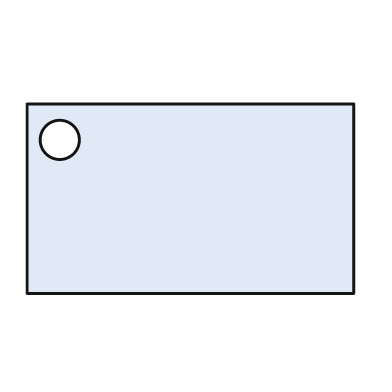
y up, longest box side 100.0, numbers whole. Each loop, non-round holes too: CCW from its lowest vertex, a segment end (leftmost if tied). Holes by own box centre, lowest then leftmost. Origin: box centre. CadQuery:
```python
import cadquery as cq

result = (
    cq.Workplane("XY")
    .moveTo(-50.0, -29.0)
    .lineTo(50.0, -29.0)
    .lineTo(50.0, 29.0)
    .lineTo(-50.0, 29.0)
    .close()
    .moveTo(-40.0, 18.0)
    .circle(6.0)
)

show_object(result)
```